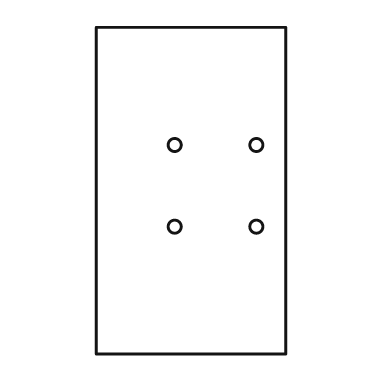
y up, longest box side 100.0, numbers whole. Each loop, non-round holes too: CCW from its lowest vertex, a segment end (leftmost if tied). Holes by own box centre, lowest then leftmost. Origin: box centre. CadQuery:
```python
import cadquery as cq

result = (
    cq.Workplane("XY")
    .moveTo(-29.0, -50.0)
    .lineTo(29.0, -50.0)
    .lineTo(29.0, 50.0)
    .lineTo(-29.0, 50.0)
    .close()
    .moveTo(-5.0, -11.0)
    .circle(2.0)
    .moveTo(20.0, -11.0)
    .circle(2.0)
    .moveTo(-5.0, 14.0)
    .circle(2.0)
    .moveTo(20.0, 14.0)
    .circle(2.0)
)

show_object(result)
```